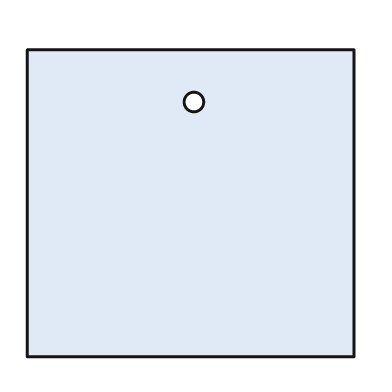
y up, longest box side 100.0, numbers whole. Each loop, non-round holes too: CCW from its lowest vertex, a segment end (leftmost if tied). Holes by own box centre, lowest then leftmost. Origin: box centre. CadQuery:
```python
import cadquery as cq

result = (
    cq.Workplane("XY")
    .moveTo(-50.0, -47.0)
    .lineTo(50.0, -47.0)
    .lineTo(50.0, 47.0)
    .lineTo(-50.0, 47.0)
    .close()
    .moveTo(1.0, 31.0)
    .circle(3.0)
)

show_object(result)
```